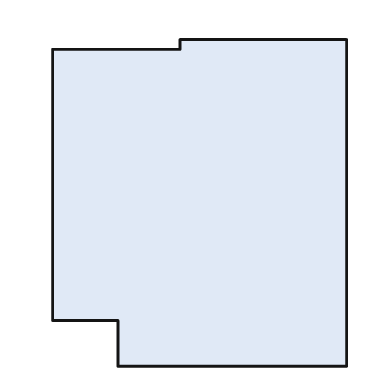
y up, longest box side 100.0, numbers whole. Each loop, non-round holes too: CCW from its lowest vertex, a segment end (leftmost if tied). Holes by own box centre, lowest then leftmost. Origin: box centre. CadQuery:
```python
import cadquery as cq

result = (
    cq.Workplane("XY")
    .moveTo(-25.0, -50.0)
    .lineTo(45.0, -50.0)
    .lineTo(45.0, 50.0)
    .lineTo(-6.0, 50.0)
    .lineTo(-6.0, 47.0)
    .lineTo(-45.0, 47.0)
    .lineTo(-45.0, -36.0)
    .lineTo(-25.0, -36.0)
    .close()
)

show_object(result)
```